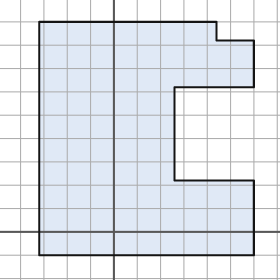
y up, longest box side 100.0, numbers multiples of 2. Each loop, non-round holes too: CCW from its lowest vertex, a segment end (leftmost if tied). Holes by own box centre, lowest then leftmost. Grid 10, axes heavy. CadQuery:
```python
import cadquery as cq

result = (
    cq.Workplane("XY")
    .moveTo(-32.0, -10.0)
    .lineTo(60.0, -10.0)
    .lineTo(60.0, 22.0)
    .lineTo(26.0, 22.0)
    .lineTo(26.0, 62.0)
    .lineTo(60.0, 62.0)
    .lineTo(60.0, 82.0)
    .lineTo(44.0, 82.0)
    .lineTo(44.0, 90.0)
    .lineTo(-32.0, 90.0)
    .close()
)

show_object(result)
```